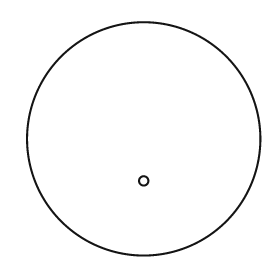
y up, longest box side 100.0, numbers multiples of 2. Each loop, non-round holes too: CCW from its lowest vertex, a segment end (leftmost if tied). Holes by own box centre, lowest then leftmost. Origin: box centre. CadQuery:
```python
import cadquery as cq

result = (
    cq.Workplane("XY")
    .moveTo(0.0, 0.0)
    .circle(50.0)
    .moveTo(0.0, -18.0)
    .circle(2.0)
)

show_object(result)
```